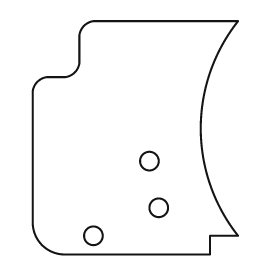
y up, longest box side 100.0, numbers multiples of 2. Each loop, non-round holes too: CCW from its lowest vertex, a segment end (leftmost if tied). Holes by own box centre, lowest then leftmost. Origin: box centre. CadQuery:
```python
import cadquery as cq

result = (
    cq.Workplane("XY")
    .moveTo(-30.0, -50.0)
    .lineTo(32.0, -50.0)
    .lineTo(32.0, -42.0)
    .lineTo(44.0, -42.0)
    .threePointArc((28.0, 4.0), (44.0, 50.0))
    .lineTo(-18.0, 50.0)
    .threePointArc((-22.0, 48.0), (-24.0, 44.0))
    .lineTo(-24.0, 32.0)
    .threePointArc((-26.0, 28.0), (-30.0, 26.0))
    .lineTo(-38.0, 26.0)
    .threePointArc((-42.0, 24.0), (-44.0, 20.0))
    .lineTo(-44.0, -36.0)
    .threePointArc((-40.0, -46.0), (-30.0, -50.0))
    .close()
    .moveTo(-18.0, -42.0)
    .circle(4.0)
    .moveTo(10.0, -30.0)
    .circle(4.0)
    .moveTo(6.0, -10.0)
    .circle(4.0)
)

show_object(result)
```